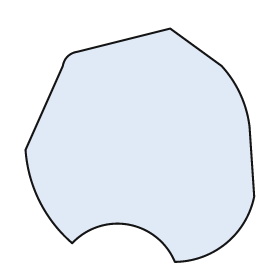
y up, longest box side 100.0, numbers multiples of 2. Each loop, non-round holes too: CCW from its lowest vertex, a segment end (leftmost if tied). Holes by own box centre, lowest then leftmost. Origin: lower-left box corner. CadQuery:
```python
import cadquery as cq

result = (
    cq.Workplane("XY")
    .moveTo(64.0, 0.0)
    .threePointArc((86.0, 8.0), (98.0, 28.0))
    .lineTo(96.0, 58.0)
    .threePointArc((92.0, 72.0), (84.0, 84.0))
    .lineTo(62.0, 100.0)
    .lineTo(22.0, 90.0)
    .threePointArc((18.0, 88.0), (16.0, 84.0))
    .lineTo(0.0, 48.0)
    .threePointArc((6.0, 26.0), (20.0, 8.0))
    .threePointArc((44.0, 16.0), (64.0, 0.0))
    .close()
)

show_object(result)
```